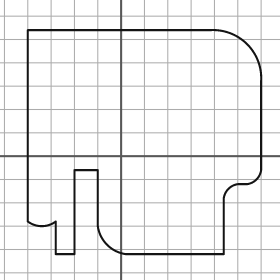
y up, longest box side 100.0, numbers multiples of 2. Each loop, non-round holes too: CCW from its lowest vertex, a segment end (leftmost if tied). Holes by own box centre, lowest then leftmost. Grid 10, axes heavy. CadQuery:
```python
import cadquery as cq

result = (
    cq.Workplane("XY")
    .moveTo(-28.0, -42.0)
    .lineTo(-20.0, -42.0)
    .lineTo(-20.0, -6.0)
    .lineTo(-10.0, -6.0)
    .lineTo(-10.0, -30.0)
    .threePointArc((-6.0, -38.0), (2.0, -42.0))
    .lineTo(44.0, -42.0)
    .lineTo(44.0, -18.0)
    .threePointArc((46.0, -14.0), (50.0, -12.0))
    .lineTo(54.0, -12.0)
    .threePointArc((58.0, -10.0), (60.0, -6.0))
    .lineTo(60.0, 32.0)
    .threePointArc((54.0, 48.0), (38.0, 54.0))
    .lineTo(-40.0, 54.0)
    .lineTo(-40.0, -28.0)
    .threePointArc((-34.0, -30.0), (-28.0, -28.0))
    .close()
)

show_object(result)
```